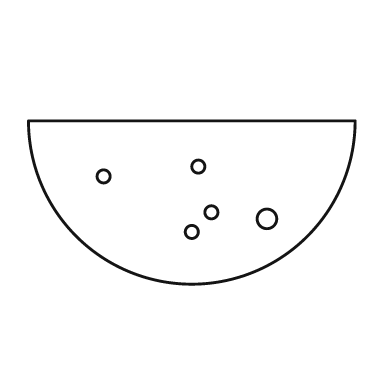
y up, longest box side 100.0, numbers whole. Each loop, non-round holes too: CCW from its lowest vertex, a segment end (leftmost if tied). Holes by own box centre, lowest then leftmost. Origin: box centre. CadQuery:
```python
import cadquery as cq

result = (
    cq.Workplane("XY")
    .moveTo(-50.0, 25.0)
    .threePointArc((0.0, -25.0), (50.0, 25.0))
    .close()
    .moveTo(0.0, -9.0)
    .circle(2.0)
    .moveTo(23.0, -5.0)
    .circle(3.0)
    .moveTo(6.0, -3.0)
    .circle(2.0)
    .moveTo(-27.0, 8.0)
    .circle(2.0)
    .moveTo(2.0, 11.0)
    .circle(2.0)
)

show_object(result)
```